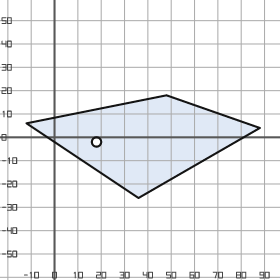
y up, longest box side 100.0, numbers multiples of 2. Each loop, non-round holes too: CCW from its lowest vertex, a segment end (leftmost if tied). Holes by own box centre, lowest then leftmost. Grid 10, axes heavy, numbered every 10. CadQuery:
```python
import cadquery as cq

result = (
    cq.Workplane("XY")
    .moveTo(36.0, -26.0)
    .lineTo(88.0, 4.0)
    .lineTo(48.0, 18.0)
    .lineTo(-12.0, 6.0)
    .close()
    .moveTo(18.0, -2.0)
    .circle(2.0)
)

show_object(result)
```